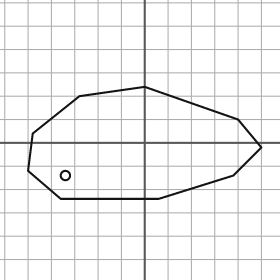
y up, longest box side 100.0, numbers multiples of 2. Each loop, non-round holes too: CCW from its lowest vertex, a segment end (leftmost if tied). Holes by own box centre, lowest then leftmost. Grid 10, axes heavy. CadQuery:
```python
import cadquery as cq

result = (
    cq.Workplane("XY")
    .moveTo(-36.0, -24.0)
    .lineTo(6.0, -24.0)
    .lineTo(38.0, -14.0)
    .lineTo(50.0, -2.0)
    .lineTo(40.0, 10.0)
    .lineTo(0.0, 24.0)
    .lineTo(-28.0, 20.0)
    .lineTo(-48.0, 4.0)
    .lineTo(-50.0, -12.0)
    .close()
    .moveTo(-34.0, -14.0)
    .circle(2.0)
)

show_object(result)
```